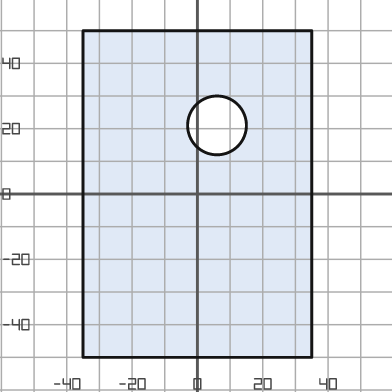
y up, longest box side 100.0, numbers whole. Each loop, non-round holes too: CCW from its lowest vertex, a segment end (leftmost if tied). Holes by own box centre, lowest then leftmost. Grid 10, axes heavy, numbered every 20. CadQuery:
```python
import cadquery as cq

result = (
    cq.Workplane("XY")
    .moveTo(-35.0, -50.0)
    .lineTo(35.0, -50.0)
    .lineTo(35.0, 50.0)
    .lineTo(-35.0, 50.0)
    .close()
    .moveTo(6.0, 21.0)
    .circle(9.0)
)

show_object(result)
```